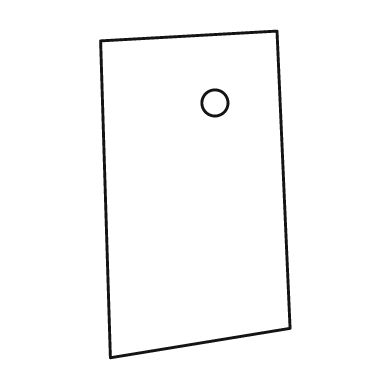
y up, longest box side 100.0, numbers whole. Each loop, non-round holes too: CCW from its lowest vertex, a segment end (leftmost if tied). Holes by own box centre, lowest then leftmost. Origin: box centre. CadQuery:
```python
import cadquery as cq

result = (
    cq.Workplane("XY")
    .moveTo(-26.0, -50.0)
    .lineTo(29.0, -41.0)
    .lineTo(25.0, 50.0)
    .lineTo(-29.0, 47.0)
    .close()
    .moveTo(6.0, 28.0)
    .circle(4.0)
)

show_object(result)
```